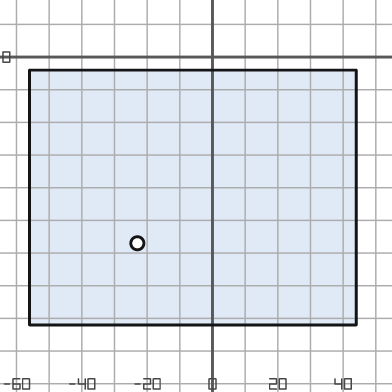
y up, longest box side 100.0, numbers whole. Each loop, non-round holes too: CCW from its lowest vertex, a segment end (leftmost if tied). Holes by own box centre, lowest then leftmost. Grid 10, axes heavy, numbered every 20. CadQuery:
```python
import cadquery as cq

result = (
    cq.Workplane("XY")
    .moveTo(-56.0, -82.0)
    .lineTo(44.0, -82.0)
    .lineTo(44.0, -4.0)
    .lineTo(-56.0, -4.0)
    .close()
    .moveTo(-23.0, -57.0)
    .circle(2.0)
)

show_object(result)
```